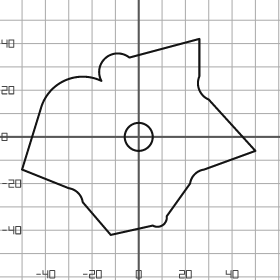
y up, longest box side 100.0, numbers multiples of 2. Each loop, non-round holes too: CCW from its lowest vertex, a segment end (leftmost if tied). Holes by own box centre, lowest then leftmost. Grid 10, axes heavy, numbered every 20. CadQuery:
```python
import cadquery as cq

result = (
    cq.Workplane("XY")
    .moveTo(-12.0, -42.0)
    .lineTo(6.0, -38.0)
    .threePointArc((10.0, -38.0), (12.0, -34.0))
    .lineTo(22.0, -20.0)
    .threePointArc((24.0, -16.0), (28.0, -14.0))
    .lineTo(50.0, -6.0)
    .lineTo(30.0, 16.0)
    .threePointArc((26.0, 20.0), (26.0, 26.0))
    .lineTo(26.0, 42.0)
    .lineTo(-4.0, 34.0)
    .threePointArc((-14.0, 34.0), (-16.0, 24.0))
    .threePointArc((-32.0, 24.0), (-42.0, 12.0))
    .lineTo(-50.0, -14.0)
    .lineTo(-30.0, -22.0)
    .threePointArc((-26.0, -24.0), (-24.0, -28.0))
    .close()
    .moveTo(0.0, 0.0)
    .circle(6.0)
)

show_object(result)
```